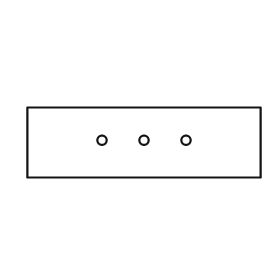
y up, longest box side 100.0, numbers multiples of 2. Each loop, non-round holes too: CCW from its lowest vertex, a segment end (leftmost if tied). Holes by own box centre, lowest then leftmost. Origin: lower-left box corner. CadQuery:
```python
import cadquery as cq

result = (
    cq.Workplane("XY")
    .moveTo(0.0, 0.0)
    .lineTo(100.0, 0.0)
    .lineTo(100.0, 30.0)
    .lineTo(0.0, 30.0)
    .close()
    .moveTo(32.0, 16.0)
    .circle(2.0)
    .moveTo(50.0, 16.0)
    .circle(2.0)
    .moveTo(68.0, 16.0)
    .circle(2.0)
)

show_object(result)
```